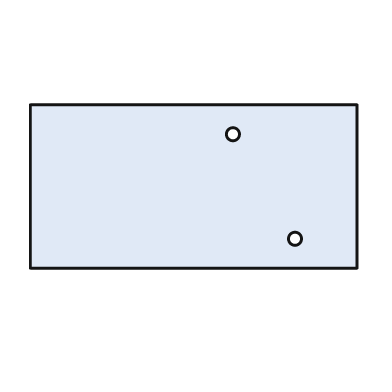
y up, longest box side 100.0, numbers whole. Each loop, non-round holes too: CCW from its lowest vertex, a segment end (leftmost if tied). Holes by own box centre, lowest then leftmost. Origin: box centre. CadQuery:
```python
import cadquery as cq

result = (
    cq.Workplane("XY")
    .moveTo(-50.0, -25.0)
    .lineTo(50.0, -25.0)
    .lineTo(50.0, 25.0)
    .lineTo(-50.0, 25.0)
    .close()
    .moveTo(31.0, -16.0)
    .circle(2.0)
    .moveTo(12.0, 16.0)
    .circle(2.0)
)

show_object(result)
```